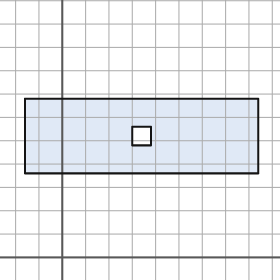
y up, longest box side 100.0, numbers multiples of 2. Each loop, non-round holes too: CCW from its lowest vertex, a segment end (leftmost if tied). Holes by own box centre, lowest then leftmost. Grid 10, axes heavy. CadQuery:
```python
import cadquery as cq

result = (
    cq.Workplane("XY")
    .moveTo(-16.0, 36.0)
    .lineTo(84.0, 36.0)
    .lineTo(84.0, 68.0)
    .lineTo(-16.0, 68.0)
    .close()
    .moveTo(30.0, 48.0)
    .lineTo(38.0, 48.0)
    .lineTo(38.0, 56.0)
    .lineTo(30.0, 56.0)
    .close()
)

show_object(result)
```